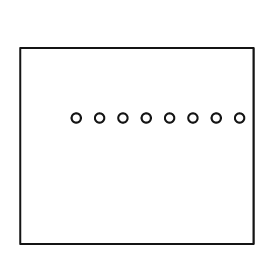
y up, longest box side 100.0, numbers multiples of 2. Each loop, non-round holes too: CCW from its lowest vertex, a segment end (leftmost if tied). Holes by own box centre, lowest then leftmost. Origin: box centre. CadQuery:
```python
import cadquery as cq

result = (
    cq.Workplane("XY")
    .moveTo(-50.0, -42.0)
    .lineTo(50.0, -42.0)
    .lineTo(50.0, 42.0)
    .lineTo(-50.0, 42.0)
    .close()
    .moveTo(-26.0, 12.0)
    .circle(2.0)
    .moveTo(-16.0, 12.0)
    .circle(2.0)
    .moveTo(-6.0, 12.0)
    .circle(2.0)
    .moveTo(4.0, 12.0)
    .circle(2.0)
    .moveTo(14.0, 12.0)
    .circle(2.0)
    .moveTo(24.0, 12.0)
    .circle(2.0)
    .moveTo(34.0, 12.0)
    .circle(2.0)
    .moveTo(44.0, 12.0)
    .circle(2.0)
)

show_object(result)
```